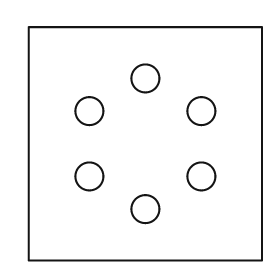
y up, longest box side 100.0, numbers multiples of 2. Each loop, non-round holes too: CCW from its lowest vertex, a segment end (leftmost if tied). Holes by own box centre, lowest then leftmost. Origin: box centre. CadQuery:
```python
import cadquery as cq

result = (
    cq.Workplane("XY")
    .moveTo(-50.0, -50.0)
    .lineTo(50.0, -50.0)
    .lineTo(50.0, 50.0)
    .lineTo(-50.0, 50.0)
    .close()
    .moveTo(0.0, -28.0)
    .circle(6.0)
    .moveTo(-24.0, -14.0)
    .circle(6.0)
    .moveTo(24.0, -14.0)
    .circle(6.0)
    .moveTo(-24.0, 14.0)
    .circle(6.0)
    .moveTo(24.0, 14.0)
    .circle(6.0)
    .moveTo(0.0, 28.0)
    .circle(6.0)
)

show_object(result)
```